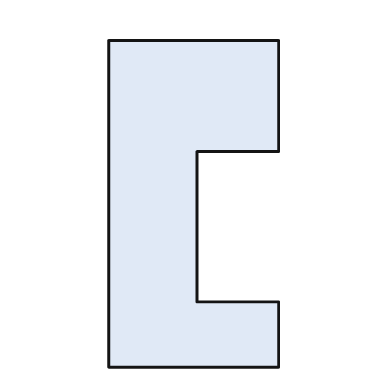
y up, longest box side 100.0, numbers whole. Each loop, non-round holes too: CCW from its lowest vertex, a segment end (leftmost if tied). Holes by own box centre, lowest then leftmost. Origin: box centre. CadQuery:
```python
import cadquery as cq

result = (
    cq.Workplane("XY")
    .moveTo(-26.0, -50.0)
    .lineTo(26.0, -50.0)
    .lineTo(26.0, -30.0)
    .lineTo(1.0, -30.0)
    .lineTo(1.0, 16.0)
    .lineTo(26.0, 16.0)
    .lineTo(26.0, 50.0)
    .lineTo(-26.0, 50.0)
    .close()
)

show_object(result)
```